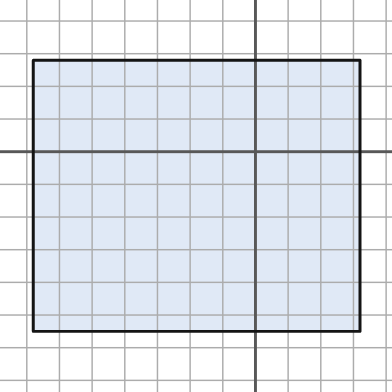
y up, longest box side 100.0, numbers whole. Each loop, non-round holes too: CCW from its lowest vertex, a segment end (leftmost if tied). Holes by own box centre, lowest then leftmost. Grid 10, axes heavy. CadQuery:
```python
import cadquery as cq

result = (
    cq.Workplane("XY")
    .moveTo(-68.0, -55.0)
    .lineTo(32.0, -55.0)
    .lineTo(32.0, 28.0)
    .lineTo(-68.0, 28.0)
    .close()
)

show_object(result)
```